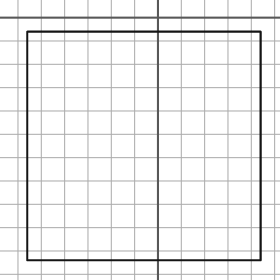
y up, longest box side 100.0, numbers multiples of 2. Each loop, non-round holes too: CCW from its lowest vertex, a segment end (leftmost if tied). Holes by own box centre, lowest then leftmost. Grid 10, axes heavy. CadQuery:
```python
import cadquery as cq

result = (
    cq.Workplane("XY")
    .moveTo(-56.0, -104.0)
    .lineTo(44.0, -104.0)
    .lineTo(44.0, -6.0)
    .lineTo(-56.0, -6.0)
    .close()
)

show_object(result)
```